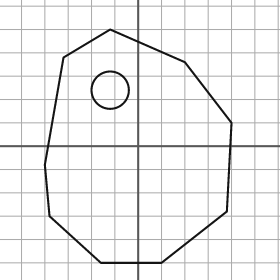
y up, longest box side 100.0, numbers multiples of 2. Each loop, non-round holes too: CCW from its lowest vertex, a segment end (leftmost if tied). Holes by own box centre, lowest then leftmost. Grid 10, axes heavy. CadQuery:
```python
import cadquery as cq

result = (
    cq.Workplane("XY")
    .moveTo(-16.0, -50.0)
    .lineTo(10.0, -50.0)
    .lineTo(38.0, -28.0)
    .lineTo(40.0, 10.0)
    .lineTo(20.0, 36.0)
    .lineTo(-12.0, 50.0)
    .lineTo(-32.0, 38.0)
    .lineTo(-40.0, -8.0)
    .lineTo(-38.0, -30.0)
    .close()
    .moveTo(-12.0, 24.0)
    .circle(8.0)
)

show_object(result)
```